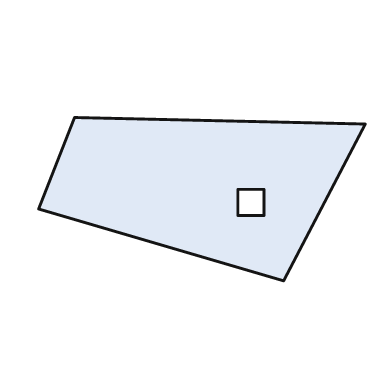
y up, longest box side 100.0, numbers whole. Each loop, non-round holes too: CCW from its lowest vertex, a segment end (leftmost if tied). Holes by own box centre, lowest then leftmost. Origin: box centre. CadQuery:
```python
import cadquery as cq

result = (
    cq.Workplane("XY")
    .moveTo(25.0, -25.0)
    .lineTo(50.0, 23.0)
    .lineTo(-39.0, 25.0)
    .lineTo(-50.0, -3.0)
    .close()
    .moveTo(11.0, -5.0)
    .lineTo(19.0, -5.0)
    .lineTo(19.0, 3.0)
    .lineTo(11.0, 3.0)
    .close()
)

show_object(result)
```